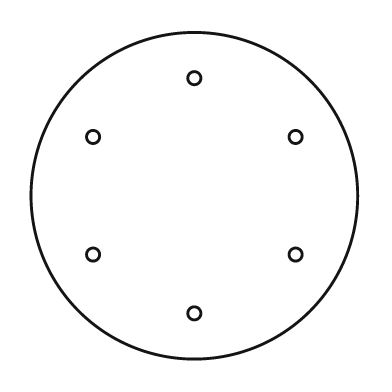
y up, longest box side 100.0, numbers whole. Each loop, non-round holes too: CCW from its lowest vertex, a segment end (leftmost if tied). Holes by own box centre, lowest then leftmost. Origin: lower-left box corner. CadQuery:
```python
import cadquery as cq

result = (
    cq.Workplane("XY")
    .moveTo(50.0, 50.0)
    .circle(50.0)
    .moveTo(50.0, 14.0)
    .circle(2.0)
    .moveTo(19.0, 32.0)
    .circle(2.0)
    .moveTo(81.0, 32.0)
    .circle(2.0)
    .moveTo(19.0, 68.0)
    .circle(2.0)
    .moveTo(81.0, 68.0)
    .circle(2.0)
    .moveTo(50.0, 86.0)
    .circle(2.0)
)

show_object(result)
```